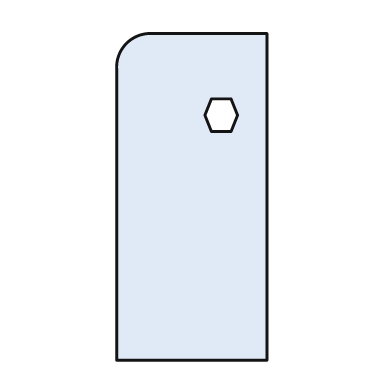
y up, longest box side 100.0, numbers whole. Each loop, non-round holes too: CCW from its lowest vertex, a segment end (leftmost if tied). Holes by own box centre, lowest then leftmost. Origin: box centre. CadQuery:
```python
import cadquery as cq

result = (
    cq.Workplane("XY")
    .moveTo(-23.0, -50.0)
    .lineTo(23.0, -50.0)
    .lineTo(23.0, 50.0)
    .lineTo(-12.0, 50.0)
    .threePointArc((-20.0, 47.0), (-23.0, 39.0))
    .close()
    .moveTo(6.0, 20.0)
    .lineTo(12.0, 20.0)
    .lineTo(14.0, 25.0)
    .lineTo(12.0, 30.0)
    .lineTo(6.0, 30.0)
    .lineTo(4.0, 25.0)
    .close()
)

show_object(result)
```